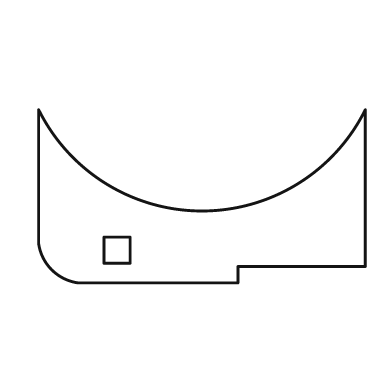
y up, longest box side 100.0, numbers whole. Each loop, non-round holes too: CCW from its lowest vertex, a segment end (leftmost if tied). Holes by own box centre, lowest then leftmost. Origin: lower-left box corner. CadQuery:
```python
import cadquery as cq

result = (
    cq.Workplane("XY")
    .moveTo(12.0, 0.0)
    .lineTo(61.0, 0.0)
    .lineTo(61.0, 5.0)
    .lineTo(100.0, 5.0)
    .lineTo(100.0, 53.0)
    .threePointArc((50.0, 22.0), (0.0, 53.0))
    .lineTo(0.0, 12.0)
    .threePointArc((4.0, 4.0), (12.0, 0.0))
    .close()
    .moveTo(20.0, 6.0)
    .lineTo(28.0, 6.0)
    .lineTo(28.0, 14.0)
    .lineTo(20.0, 14.0)
    .close()
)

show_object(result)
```